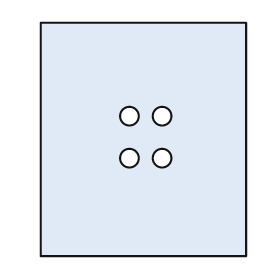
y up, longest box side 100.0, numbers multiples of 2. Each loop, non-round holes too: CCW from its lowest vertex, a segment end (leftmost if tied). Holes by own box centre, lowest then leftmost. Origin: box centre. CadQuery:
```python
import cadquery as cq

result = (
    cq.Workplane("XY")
    .moveTo(-44.0, -50.0)
    .lineTo(44.0, -50.0)
    .lineTo(44.0, 50.0)
    .lineTo(-44.0, 50.0)
    .close()
    .moveTo(-6.0, -8.0)
    .circle(4.0)
    .moveTo(8.0, -8.0)
    .circle(4.0)
    .moveTo(-6.0, 10.0)
    .circle(4.0)
    .moveTo(8.0, 10.0)
    .circle(4.0)
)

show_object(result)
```